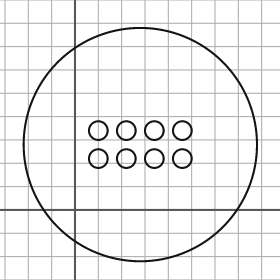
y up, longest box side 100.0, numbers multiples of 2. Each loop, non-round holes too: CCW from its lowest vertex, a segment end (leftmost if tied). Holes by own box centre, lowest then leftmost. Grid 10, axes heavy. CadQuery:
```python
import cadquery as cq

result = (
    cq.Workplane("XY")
    .moveTo(28.0, 28.0)
    .circle(50.0)
    .moveTo(10.0, 22.0)
    .circle(4.0)
    .moveTo(22.0, 22.0)
    .circle(4.0)
    .moveTo(34.0, 22.0)
    .circle(4.0)
    .moveTo(46.0, 22.0)
    .circle(4.0)
    .moveTo(10.0, 34.0)
    .circle(4.0)
    .moveTo(22.0, 34.0)
    .circle(4.0)
    .moveTo(34.0, 34.0)
    .circle(4.0)
    .moveTo(46.0, 34.0)
    .circle(4.0)
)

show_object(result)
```